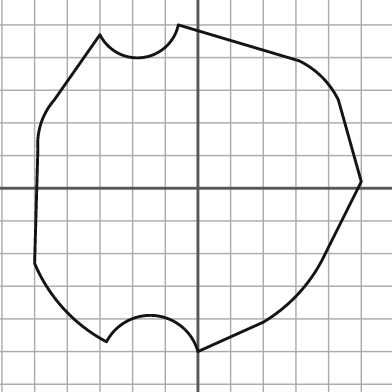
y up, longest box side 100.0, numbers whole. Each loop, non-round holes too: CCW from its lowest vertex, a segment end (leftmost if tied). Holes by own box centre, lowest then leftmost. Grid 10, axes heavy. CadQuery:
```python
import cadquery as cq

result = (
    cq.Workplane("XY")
    .moveTo(0.0, -50.0)
    .lineTo(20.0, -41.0)
    .threePointArc((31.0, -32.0), (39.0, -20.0))
    .lineTo(50.0, 2.0)
    .lineTo(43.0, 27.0)
    .threePointArc((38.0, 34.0), (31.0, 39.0))
    .lineTo(-6.0, 50.0)
    .threePointArc((-17.0, 40.0), (-30.0, 47.0))
    .lineTo(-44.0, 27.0)
    .threePointArc((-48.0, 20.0), (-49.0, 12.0))
    .lineTo(-50.0, -23.0)
    .threePointArc((-41.0, -37.0), (-28.0, -47.0))
    .threePointArc((-13.0, -39.0), (0.0, -50.0))
    .close()
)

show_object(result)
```